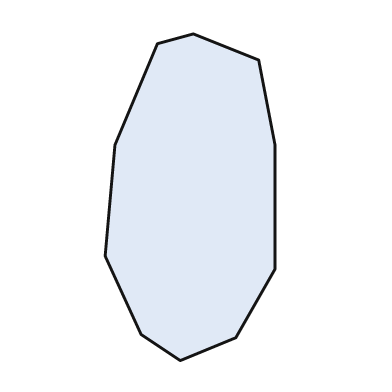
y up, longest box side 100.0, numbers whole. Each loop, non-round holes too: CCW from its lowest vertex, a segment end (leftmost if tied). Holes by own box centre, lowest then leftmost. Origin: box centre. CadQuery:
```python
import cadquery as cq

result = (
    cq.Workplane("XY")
    .moveTo(-3.0, -50.0)
    .lineTo(14.0, -43.0)
    .lineTo(26.0, -22.0)
    .lineTo(26.0, 16.0)
    .lineTo(21.0, 42.0)
    .lineTo(1.0, 50.0)
    .lineTo(-10.0, 47.0)
    .lineTo(-23.0, 16.0)
    .lineTo(-26.0, -18.0)
    .lineTo(-15.0, -42.0)
    .close()
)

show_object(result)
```